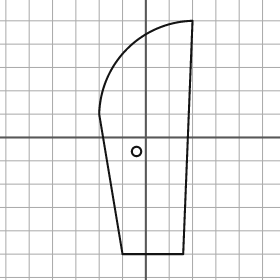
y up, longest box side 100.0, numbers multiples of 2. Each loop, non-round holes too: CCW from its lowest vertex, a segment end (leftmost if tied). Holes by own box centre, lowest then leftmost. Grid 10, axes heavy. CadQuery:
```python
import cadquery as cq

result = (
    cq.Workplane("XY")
    .moveTo(-10.0, -50.0)
    .lineTo(16.0, -50.0)
    .lineTo(20.0, 50.0)
    .threePointArc((-8.0, 38.0), (-20.0, 10.0))
    .close()
    .moveTo(-4.0, -6.0)
    .circle(2.0)
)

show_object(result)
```